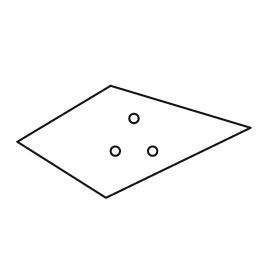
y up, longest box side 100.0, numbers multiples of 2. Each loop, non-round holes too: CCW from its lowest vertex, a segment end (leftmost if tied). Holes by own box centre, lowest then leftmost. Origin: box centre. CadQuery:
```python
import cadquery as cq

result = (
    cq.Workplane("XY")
    .moveTo(-12.0, -24.0)
    .lineTo(50.0, 6.0)
    .lineTo(-10.0, 24.0)
    .lineTo(-50.0, 0.0)
    .close()
    .moveTo(-8.0, -4.0)
    .circle(2.0)
    .moveTo(8.0, -4.0)
    .circle(2.0)
    .moveTo(0.0, 10.0)
    .circle(2.0)
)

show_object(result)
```